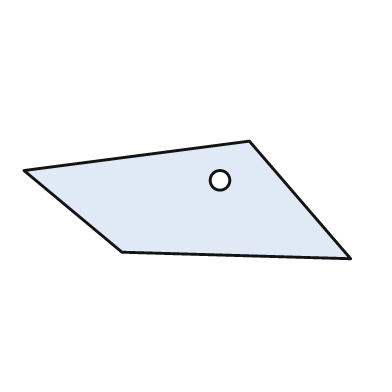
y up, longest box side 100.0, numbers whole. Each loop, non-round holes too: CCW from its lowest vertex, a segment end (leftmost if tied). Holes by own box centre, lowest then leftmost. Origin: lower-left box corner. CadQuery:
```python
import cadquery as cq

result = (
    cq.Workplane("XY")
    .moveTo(100.0, 0.0)
    .lineTo(69.0, 36.0)
    .lineTo(0.0, 27.0)
    .lineTo(30.0, 2.0)
    .close()
    .moveTo(60.0, 24.0)
    .circle(3.0)
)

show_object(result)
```